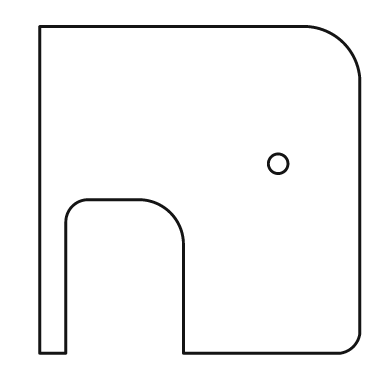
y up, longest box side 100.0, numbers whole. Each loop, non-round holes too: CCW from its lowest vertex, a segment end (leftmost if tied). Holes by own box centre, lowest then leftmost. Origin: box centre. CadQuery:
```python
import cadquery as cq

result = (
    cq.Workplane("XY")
    .moveTo(-49.0, -50.0)
    .lineTo(-41.0, -50.0)
    .lineTo(-41.0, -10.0)
    .threePointArc((-39.0, -5.0), (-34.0, -3.0))
    .lineTo(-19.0, -3.0)
    .threePointArc((-9.0, -7.0), (-5.0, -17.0))
    .lineTo(-5.0, -50.0)
    .lineTo(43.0, -50.0)
    .threePointArc((47.0, -48.0), (49.0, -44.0))
    .lineTo(49.0, 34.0)
    .threePointArc((44.0, 45.0), (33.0, 50.0))
    .lineTo(-49.0, 50.0)
    .close()
    .moveTo(24.0, 8.0)
    .circle(3.0)
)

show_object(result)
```